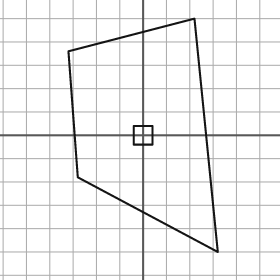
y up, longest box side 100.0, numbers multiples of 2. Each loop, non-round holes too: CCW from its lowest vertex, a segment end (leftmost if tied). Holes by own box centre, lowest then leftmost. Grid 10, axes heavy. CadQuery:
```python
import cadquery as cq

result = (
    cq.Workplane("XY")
    .moveTo(32.0, -50.0)
    .lineTo(22.0, 50.0)
    .lineTo(-32.0, 36.0)
    .lineTo(-28.0, -18.0)
    .close()
    .moveTo(-4.0, -4.0)
    .lineTo(4.0, -4.0)
    .lineTo(4.0, 4.0)
    .lineTo(-4.0, 4.0)
    .close()
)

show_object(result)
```